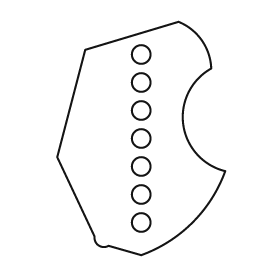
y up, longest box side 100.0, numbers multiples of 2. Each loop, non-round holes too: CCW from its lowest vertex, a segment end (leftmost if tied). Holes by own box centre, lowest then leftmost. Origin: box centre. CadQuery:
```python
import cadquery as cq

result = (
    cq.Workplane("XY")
    .moveTo(0.0, -50.0)
    .threePointArc((22.0, -36.0), (36.0, -14.0))
    .threePointArc((18.0, 6.0), (30.0, 30.0))
    .threePointArc((26.0, 42.0), (16.0, 50.0))
    .lineTo(-24.0, 38.0)
    .lineTo(-36.0, -8.0)
    .lineTo(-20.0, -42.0)
    .threePointArc((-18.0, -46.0), (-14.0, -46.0))
    .close()
    .moveTo(0.0, -36.0)
    .circle(4.0)
    .moveTo(0.0, -24.0)
    .circle(4.0)
    .moveTo(0.0, -12.0)
    .circle(4.0)
    .moveTo(0.0, 0.0)
    .circle(4.0)
    .moveTo(0.0, 12.0)
    .circle(4.0)
    .moveTo(0.0, 24.0)
    .circle(4.0)
    .moveTo(0.0, 36.0)
    .circle(4.0)
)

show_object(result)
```